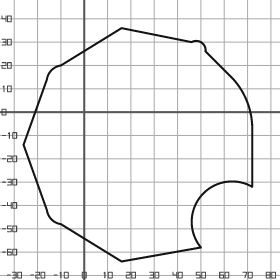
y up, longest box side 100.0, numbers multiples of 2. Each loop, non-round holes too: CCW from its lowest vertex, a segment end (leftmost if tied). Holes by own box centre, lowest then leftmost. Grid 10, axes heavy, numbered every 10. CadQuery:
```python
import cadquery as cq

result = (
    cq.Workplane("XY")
    .moveTo(16.0, -64.0)
    .lineTo(50.0, -58.0)
    .threePointArc((50.0, -36.0), (72.0, -32.0))
    .lineTo(72.0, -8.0)
    .threePointArc((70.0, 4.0), (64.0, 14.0))
    .lineTo(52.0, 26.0)
    .threePointArc((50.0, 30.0), (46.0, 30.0))
    .lineTo(16.0, 36.0)
    .lineTo(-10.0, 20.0)
    .threePointArc((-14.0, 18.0), (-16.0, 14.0))
    .lineTo(-26.0, -14.0)
    .lineTo(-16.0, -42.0)
    .threePointArc((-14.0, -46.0), (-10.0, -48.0))
    .close()
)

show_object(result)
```